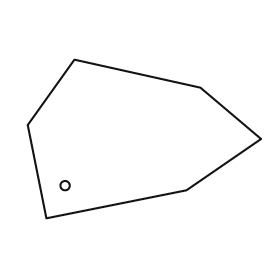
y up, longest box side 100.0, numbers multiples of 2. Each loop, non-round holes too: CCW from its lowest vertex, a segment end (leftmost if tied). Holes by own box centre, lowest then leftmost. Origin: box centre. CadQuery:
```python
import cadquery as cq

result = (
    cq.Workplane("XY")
    .moveTo(-42.0, -34.0)
    .lineTo(18.0, -22.0)
    .lineTo(50.0, 0.0)
    .lineTo(24.0, 22.0)
    .lineTo(-30.0, 34.0)
    .lineTo(-50.0, 6.0)
    .close()
    .moveTo(-34.0, -20.0)
    .circle(2.0)
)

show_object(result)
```